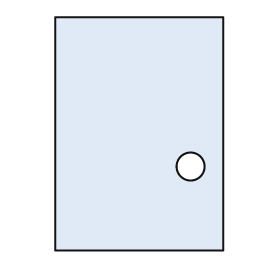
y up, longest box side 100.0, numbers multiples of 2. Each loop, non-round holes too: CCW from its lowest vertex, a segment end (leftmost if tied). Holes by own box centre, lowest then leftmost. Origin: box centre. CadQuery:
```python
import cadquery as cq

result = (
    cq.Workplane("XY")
    .moveTo(-36.0, -50.0)
    .lineTo(36.0, -50.0)
    .lineTo(36.0, 50.0)
    .lineTo(-36.0, 50.0)
    .close()
    .moveTo(22.0, -14.0)
    .circle(6.0)
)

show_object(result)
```